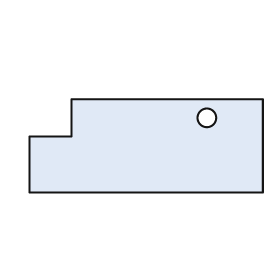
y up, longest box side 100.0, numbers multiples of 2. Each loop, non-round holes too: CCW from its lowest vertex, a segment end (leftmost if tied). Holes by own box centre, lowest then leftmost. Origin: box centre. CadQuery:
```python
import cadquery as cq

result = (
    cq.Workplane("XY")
    .moveTo(-50.0, -20.0)
    .lineTo(50.0, -20.0)
    .lineTo(50.0, 20.0)
    .lineTo(-32.0, 20.0)
    .lineTo(-32.0, 4.0)
    .lineTo(-50.0, 4.0)
    .close()
    .moveTo(26.0, 12.0)
    .circle(4.0)
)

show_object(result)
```